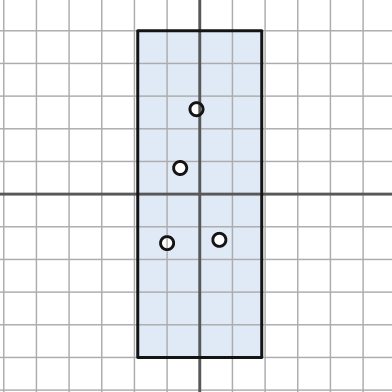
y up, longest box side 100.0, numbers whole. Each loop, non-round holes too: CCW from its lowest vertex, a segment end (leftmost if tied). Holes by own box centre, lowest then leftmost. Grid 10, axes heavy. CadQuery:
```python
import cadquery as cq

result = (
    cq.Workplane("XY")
    .moveTo(-19.0, -50.0)
    .lineTo(19.0, -50.0)
    .lineTo(19.0, 50.0)
    .lineTo(-19.0, 50.0)
    .close()
    .moveTo(-10.0, -15.0)
    .circle(2.0)
    .moveTo(6.0, -14.0)
    .circle(2.0)
    .moveTo(-6.0, 8.0)
    .circle(2.0)
    .moveTo(-1.0, 26.0)
    .circle(2.0)
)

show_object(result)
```